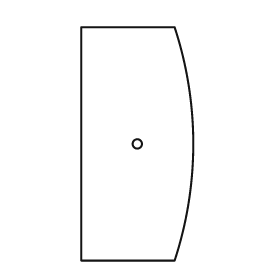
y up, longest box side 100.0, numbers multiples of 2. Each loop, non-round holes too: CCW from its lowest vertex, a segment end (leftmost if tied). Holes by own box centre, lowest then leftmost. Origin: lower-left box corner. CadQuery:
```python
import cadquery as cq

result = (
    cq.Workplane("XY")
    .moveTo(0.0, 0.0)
    .lineTo(40.0, 0.0)
    .threePointArc((48.0, 50.0), (40.0, 100.0))
    .lineTo(0.0, 100.0)
    .close()
    .moveTo(24.0, 50.0)
    .circle(2.0)
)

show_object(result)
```